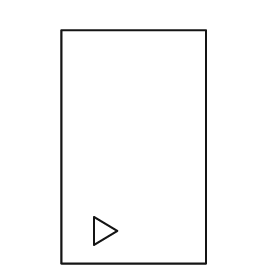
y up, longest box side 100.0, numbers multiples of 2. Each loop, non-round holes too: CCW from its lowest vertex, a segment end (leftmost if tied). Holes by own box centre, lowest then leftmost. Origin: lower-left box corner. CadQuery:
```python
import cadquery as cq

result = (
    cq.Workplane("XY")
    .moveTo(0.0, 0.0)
    .lineTo(62.0, 0.0)
    .lineTo(62.0, 100.0)
    .lineTo(0.0, 100.0)
    .close()
    .moveTo(14.0, 8.0)
    .lineTo(24.0, 14.0)
    .lineTo(14.0, 20.0)
    .close()
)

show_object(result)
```